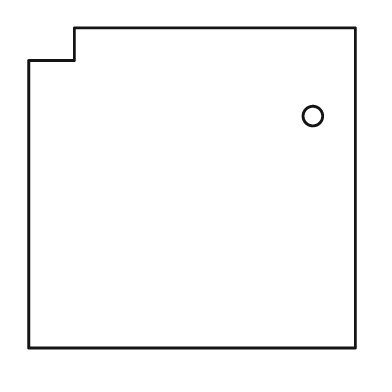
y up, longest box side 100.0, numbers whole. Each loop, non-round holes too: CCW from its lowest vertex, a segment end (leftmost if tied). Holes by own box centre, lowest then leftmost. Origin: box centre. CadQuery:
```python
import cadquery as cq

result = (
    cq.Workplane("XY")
    .moveTo(-50.0, -49.0)
    .lineTo(50.0, -49.0)
    .lineTo(50.0, 49.0)
    .lineTo(-36.0, 49.0)
    .lineTo(-36.0, 39.0)
    .lineTo(-50.0, 39.0)
    .close()
    .moveTo(37.0, 22.0)
    .circle(3.0)
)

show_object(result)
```